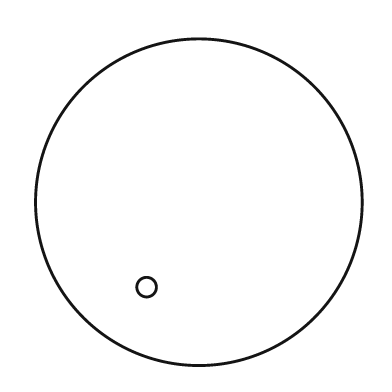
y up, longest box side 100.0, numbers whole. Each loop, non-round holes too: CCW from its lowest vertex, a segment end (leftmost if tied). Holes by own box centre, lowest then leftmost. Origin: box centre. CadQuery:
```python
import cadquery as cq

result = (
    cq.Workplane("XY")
    .moveTo(0.0, 0.0)
    .circle(50.0)
    .moveTo(-16.0, -26.0)
    .circle(3.0)
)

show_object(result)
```